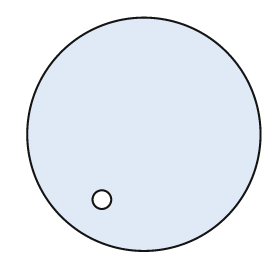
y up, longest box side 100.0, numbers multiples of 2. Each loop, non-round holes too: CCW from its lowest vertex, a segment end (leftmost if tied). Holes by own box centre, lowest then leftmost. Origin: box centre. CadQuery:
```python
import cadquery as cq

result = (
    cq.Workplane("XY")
    .moveTo(0.0, 0.0)
    .circle(50.0)
    .moveTo(-18.0, -28.0)
    .circle(4.0)
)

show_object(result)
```